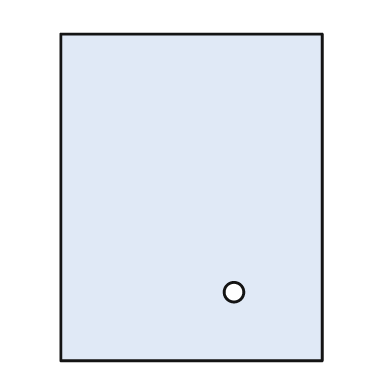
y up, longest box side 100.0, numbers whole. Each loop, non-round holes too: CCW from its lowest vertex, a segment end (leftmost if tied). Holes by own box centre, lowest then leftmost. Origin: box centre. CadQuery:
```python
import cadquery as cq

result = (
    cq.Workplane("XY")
    .moveTo(-40.0, -50.0)
    .lineTo(40.0, -50.0)
    .lineTo(40.0, 50.0)
    .lineTo(-40.0, 50.0)
    .close()
    .moveTo(13.0, -29.0)
    .circle(3.0)
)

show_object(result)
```